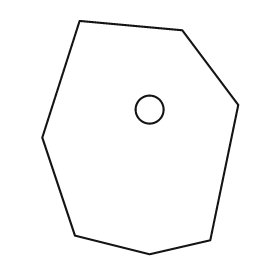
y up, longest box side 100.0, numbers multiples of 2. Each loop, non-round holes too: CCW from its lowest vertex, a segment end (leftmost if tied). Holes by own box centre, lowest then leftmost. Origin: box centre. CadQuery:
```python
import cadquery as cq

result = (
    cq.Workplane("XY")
    .moveTo(4.0, -50.0)
    .lineTo(30.0, -44.0)
    .lineTo(42.0, 14.0)
    .lineTo(18.0, 46.0)
    .lineTo(-26.0, 50.0)
    .lineTo(-42.0, 0.0)
    .lineTo(-28.0, -42.0)
    .close()
    .moveTo(4.0, 12.0)
    .circle(6.0)
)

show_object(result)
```